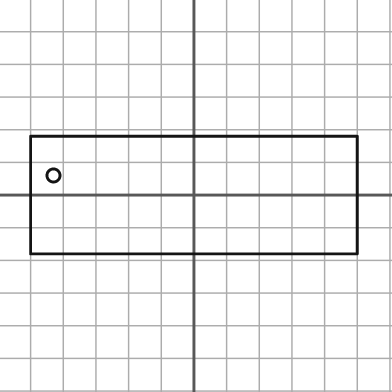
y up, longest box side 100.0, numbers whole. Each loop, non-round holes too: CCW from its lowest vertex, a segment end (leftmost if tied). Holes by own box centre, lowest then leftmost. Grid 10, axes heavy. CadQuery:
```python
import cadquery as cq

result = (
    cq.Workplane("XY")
    .moveTo(-50.0, -18.0)
    .lineTo(50.0, -18.0)
    .lineTo(50.0, 18.0)
    .lineTo(-50.0, 18.0)
    .close()
    .moveTo(-43.0, 6.0)
    .circle(2.0)
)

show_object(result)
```